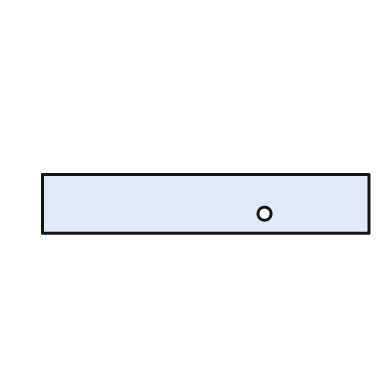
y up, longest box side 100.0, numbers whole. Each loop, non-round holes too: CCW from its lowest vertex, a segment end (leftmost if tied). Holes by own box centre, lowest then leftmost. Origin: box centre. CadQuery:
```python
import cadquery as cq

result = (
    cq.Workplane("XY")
    .moveTo(-50.0, -9.0)
    .lineTo(50.0, -9.0)
    .lineTo(50.0, 9.0)
    .lineTo(-50.0, 9.0)
    .close()
    .moveTo(18.0, -3.0)
    .circle(2.0)
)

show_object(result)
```